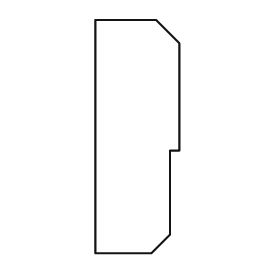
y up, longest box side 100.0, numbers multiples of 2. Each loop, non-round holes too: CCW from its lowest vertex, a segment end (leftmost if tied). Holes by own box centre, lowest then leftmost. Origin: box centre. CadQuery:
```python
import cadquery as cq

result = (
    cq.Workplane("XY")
    .moveTo(-18.0, -50.0)
    .lineTo(6.0, -50.0)
    .lineTo(14.0, -42.0)
    .lineTo(14.0, -6.0)
    .lineTo(18.0, -6.0)
    .lineTo(18.0, 40.0)
    .lineTo(8.0, 50.0)
    .lineTo(-18.0, 50.0)
    .close()
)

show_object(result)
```